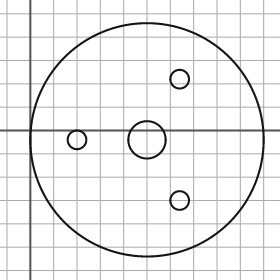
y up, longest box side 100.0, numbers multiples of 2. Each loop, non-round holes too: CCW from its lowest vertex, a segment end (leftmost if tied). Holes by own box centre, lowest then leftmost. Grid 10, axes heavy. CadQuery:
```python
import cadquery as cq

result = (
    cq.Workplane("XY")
    .moveTo(50.0, -4.0)
    .circle(50.0)
    .moveTo(64.0, -30.0)
    .circle(4.0)
    .moveTo(20.0, -4.0)
    .circle(4.0)
    .moveTo(50.0, -4.0)
    .circle(8.0)
    .moveTo(64.0, 22.0)
    .circle(4.0)
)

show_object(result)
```